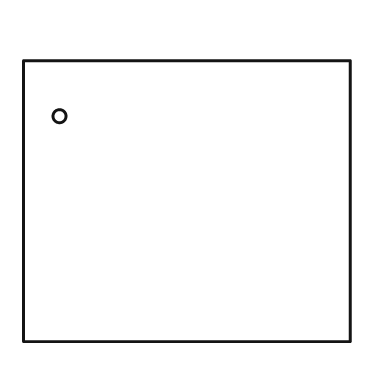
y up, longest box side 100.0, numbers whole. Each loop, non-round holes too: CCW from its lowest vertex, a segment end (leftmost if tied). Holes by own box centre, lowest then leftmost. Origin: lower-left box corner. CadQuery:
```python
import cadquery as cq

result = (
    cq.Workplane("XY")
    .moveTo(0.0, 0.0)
    .lineTo(100.0, 0.0)
    .lineTo(100.0, 86.0)
    .lineTo(0.0, 86.0)
    .close()
    .moveTo(11.0, 69.0)
    .circle(2.0)
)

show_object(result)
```